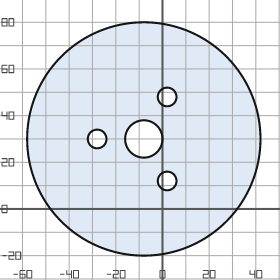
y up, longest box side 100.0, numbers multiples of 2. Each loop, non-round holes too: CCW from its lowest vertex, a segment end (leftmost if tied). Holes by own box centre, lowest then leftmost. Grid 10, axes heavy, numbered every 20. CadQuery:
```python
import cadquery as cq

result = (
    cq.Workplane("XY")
    .moveTo(-8.0, 30.0)
    .circle(50.0)
    .moveTo(2.0, 12.0)
    .circle(4.0)
    .moveTo(-28.0, 30.0)
    .circle(4.0)
    .moveTo(-8.0, 30.0)
    .circle(8.0)
    .moveTo(2.0, 48.0)
    .circle(4.0)
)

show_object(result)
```